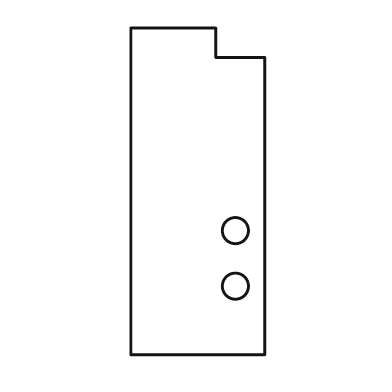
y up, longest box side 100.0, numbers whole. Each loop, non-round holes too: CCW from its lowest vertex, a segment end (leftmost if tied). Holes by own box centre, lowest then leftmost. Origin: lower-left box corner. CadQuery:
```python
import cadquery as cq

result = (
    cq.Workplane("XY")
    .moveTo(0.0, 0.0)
    .lineTo(41.0, 0.0)
    .lineTo(41.0, 91.0)
    .lineTo(26.0, 91.0)
    .lineTo(26.0, 100.0)
    .lineTo(0.0, 100.0)
    .close()
    .moveTo(32.0, 21.0)
    .circle(4.0)
    .moveTo(32.0, 38.0)
    .circle(4.0)
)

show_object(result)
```